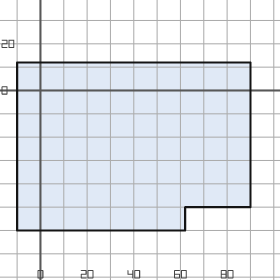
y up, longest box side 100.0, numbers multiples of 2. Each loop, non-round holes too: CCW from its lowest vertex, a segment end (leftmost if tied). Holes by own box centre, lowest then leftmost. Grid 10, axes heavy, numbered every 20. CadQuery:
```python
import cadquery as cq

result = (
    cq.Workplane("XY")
    .moveTo(-10.0, -60.0)
    .lineTo(62.0, -60.0)
    .lineTo(62.0, -50.0)
    .lineTo(90.0, -50.0)
    .lineTo(90.0, 12.0)
    .lineTo(-10.0, 12.0)
    .close()
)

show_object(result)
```